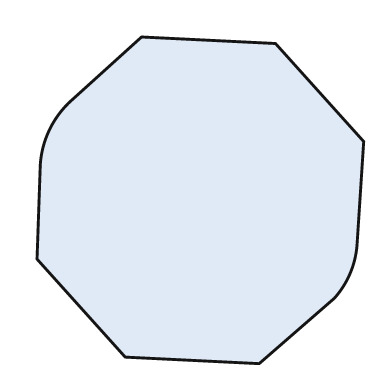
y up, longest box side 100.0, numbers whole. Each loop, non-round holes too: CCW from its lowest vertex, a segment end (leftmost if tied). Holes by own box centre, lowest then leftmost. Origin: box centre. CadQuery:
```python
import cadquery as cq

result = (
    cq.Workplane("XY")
    .moveTo(18.0, -50.0)
    .lineTo(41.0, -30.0)
    .threePointArc((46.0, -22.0), (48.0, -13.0))
    .lineTo(50.0, 18.0)
    .lineTo(23.0, 48.0)
    .lineTo(-18.0, 50.0)
    .lineTo(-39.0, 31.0)
    .threePointArc((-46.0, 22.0), (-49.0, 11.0))
    .lineTo(-50.0, -18.0)
    .lineTo(-23.0, -48.0)
    .close()
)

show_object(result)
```